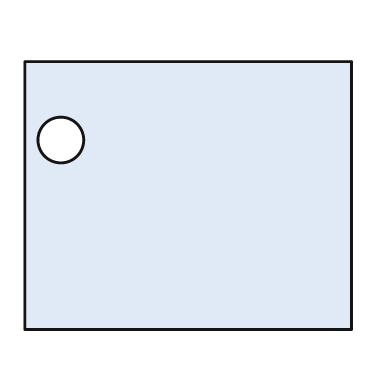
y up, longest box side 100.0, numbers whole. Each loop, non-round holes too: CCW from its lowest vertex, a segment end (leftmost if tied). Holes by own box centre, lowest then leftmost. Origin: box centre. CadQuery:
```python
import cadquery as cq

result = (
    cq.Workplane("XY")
    .moveTo(-50.0, -41.0)
    .lineTo(50.0, -41.0)
    .lineTo(50.0, 41.0)
    .lineTo(-50.0, 41.0)
    .close()
    .moveTo(-39.0, 17.0)
    .circle(7.0)
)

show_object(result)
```